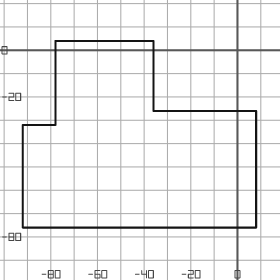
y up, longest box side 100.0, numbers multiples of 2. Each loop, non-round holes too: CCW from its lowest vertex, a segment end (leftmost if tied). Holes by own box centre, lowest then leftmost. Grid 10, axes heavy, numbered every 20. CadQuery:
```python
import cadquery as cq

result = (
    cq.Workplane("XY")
    .moveTo(-92.0, -76.0)
    .lineTo(8.0, -76.0)
    .lineTo(8.0, -26.0)
    .lineTo(-36.0, -26.0)
    .lineTo(-36.0, 4.0)
    .lineTo(-78.0, 4.0)
    .lineTo(-78.0, -32.0)
    .lineTo(-92.0, -32.0)
    .close()
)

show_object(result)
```